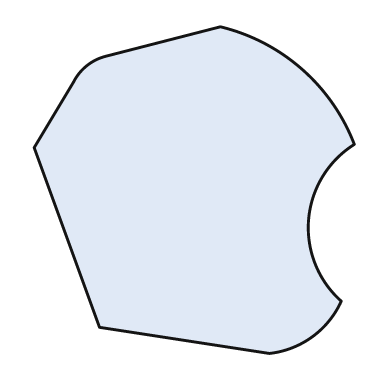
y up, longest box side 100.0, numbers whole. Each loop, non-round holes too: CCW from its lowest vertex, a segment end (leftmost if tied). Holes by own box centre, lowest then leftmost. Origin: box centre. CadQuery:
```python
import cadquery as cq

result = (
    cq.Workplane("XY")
    .moveTo(23.0, -50.0)
    .threePointArc((36.0, -45.0), (45.0, -34.0))
    .threePointArc((35.0, -9.0), (49.0, 14.0))
    .threePointArc((33.0, 37.0), (8.0, 50.0))
    .lineTo(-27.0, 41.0)
    .threePointArc((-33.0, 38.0), (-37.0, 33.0))
    .lineTo(-49.0, 13.0)
    .lineTo(-29.0, -42.0)
    .close()
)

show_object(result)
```